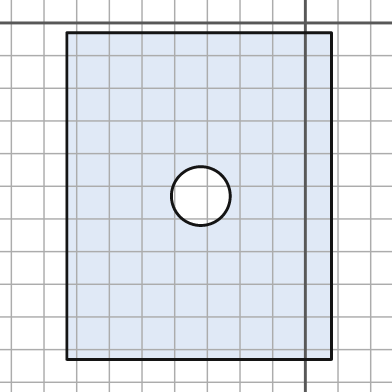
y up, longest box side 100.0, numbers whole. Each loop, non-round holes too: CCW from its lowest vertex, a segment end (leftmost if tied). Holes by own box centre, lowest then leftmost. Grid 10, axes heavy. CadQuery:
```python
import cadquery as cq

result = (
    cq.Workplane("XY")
    .moveTo(-73.0, -103.0)
    .lineTo(8.0, -103.0)
    .lineTo(8.0, -3.0)
    .lineTo(-73.0, -3.0)
    .close()
    .moveTo(-32.0, -53.0)
    .circle(9.0)
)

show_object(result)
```